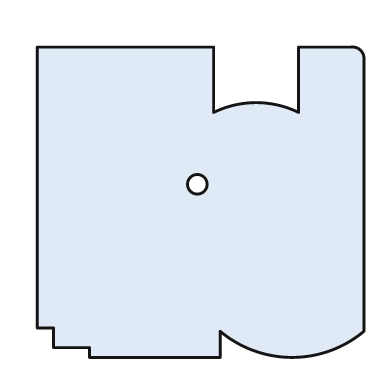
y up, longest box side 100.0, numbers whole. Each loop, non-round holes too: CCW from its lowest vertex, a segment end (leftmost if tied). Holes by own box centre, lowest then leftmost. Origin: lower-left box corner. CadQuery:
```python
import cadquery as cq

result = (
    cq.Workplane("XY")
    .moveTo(16.0, 0.0)
    .lineTo(56.0, 0.0)
    .lineTo(56.0, 8.0)
    .threePointArc((78.0, 0.0), (100.0, 8.0))
    .lineTo(100.0, 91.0)
    .threePointArc((99.0, 94.0), (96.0, 95.0))
    .lineTo(80.0, 95.0)
    .lineTo(80.0, 75.0)
    .threePointArc((67.0, 78.0), (54.0, 75.0))
    .lineTo(54.0, 95.0)
    .lineTo(0.0, 95.0)
    .lineTo(0.0, 9.0)
    .lineTo(5.0, 9.0)
    .lineTo(5.0, 3.0)
    .lineTo(16.0, 3.0)
    .close()
    .moveTo(49.0, 53.0)
    .circle(3.0)
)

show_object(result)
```